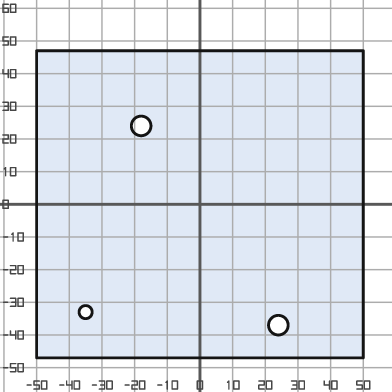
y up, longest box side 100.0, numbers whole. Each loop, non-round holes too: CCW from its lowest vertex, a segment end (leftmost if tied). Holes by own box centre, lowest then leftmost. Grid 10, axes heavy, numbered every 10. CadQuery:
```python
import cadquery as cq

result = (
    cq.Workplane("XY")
    .moveTo(-50.0, -47.0)
    .lineTo(50.0, -47.0)
    .lineTo(50.0, 47.0)
    .lineTo(-50.0, 47.0)
    .close()
    .moveTo(24.0, -37.0)
    .circle(3.0)
    .moveTo(-35.0, -33.0)
    .circle(2.0)
    .moveTo(-18.0, 24.0)
    .circle(3.0)
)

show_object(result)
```